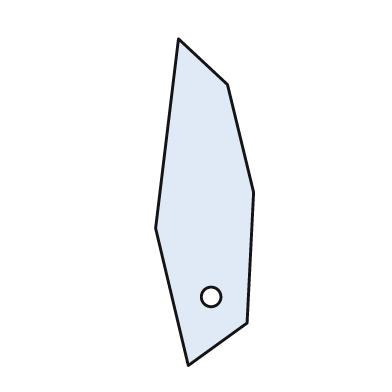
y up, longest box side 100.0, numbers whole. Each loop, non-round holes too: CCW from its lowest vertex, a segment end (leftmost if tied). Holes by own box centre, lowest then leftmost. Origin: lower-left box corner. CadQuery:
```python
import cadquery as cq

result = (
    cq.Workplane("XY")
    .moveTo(10.0, 0.0)
    .lineTo(28.0, 13.0)
    .lineTo(30.0, 53.0)
    .lineTo(22.0, 86.0)
    .lineTo(7.0, 100.0)
    .lineTo(0.0, 42.0)
    .close()
    .moveTo(17.0, 21.0)
    .circle(3.0)
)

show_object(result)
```